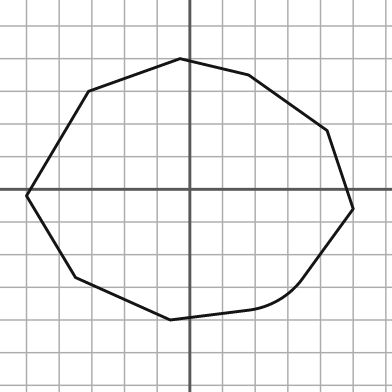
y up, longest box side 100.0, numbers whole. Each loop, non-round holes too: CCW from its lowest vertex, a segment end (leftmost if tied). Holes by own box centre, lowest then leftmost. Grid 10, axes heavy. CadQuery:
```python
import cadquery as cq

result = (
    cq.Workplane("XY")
    .moveTo(-6.0, -40.0)
    .lineTo(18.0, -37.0)
    .threePointArc((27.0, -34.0), (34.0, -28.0))
    .lineTo(50.0, -6.0)
    .lineTo(42.0, 18.0)
    .lineTo(18.0, 35.0)
    .lineTo(-3.0, 40.0)
    .lineTo(-31.0, 30.0)
    .lineTo(-50.0, -2.0)
    .lineTo(-35.0, -27.0)
    .close()
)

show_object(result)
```